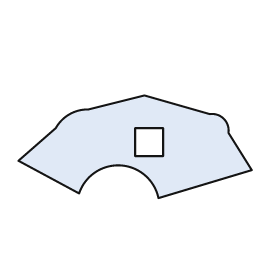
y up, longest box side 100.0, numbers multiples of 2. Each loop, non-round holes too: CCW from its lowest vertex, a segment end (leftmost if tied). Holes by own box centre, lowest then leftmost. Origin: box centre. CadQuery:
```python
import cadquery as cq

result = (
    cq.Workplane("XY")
    .moveTo(10.0, -22.0)
    .lineTo(50.0, -10.0)
    .lineTo(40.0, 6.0)
    .threePointArc((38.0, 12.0), (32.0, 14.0))
    .lineTo(4.0, 22.0)
    .lineTo(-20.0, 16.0)
    .threePointArc((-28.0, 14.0), (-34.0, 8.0))
    .lineTo(-50.0, -6.0)
    .lineTo(-24.0, -20.0)
    .threePointArc((-6.0, -8.0), (10.0, -22.0))
    .close()
    .moveTo(0.0, -4.0)
    .lineTo(12.0, -4.0)
    .lineTo(12.0, 8.0)
    .lineTo(0.0, 8.0)
    .close()
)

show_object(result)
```